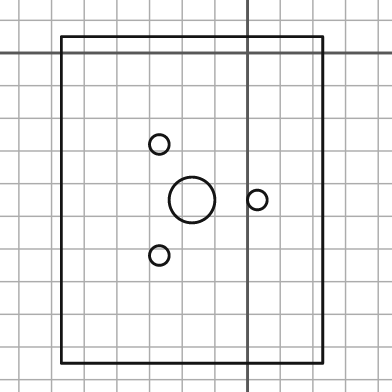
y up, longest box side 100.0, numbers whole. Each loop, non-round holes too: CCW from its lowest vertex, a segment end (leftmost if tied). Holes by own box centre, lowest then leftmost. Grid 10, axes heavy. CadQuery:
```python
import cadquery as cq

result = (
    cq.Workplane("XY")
    .moveTo(-57.0, -95.0)
    .lineTo(23.0, -95.0)
    .lineTo(23.0, 5.0)
    .lineTo(-57.0, 5.0)
    .close()
    .moveTo(-27.0, -62.0)
    .circle(3.0)
    .moveTo(-17.0, -45.0)
    .circle(7.0)
    .moveTo(3.0, -45.0)
    .circle(3.0)
    .moveTo(-27.0, -28.0)
    .circle(3.0)
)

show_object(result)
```